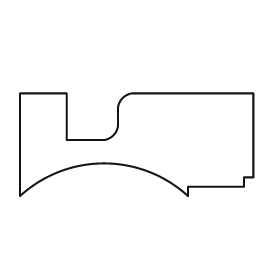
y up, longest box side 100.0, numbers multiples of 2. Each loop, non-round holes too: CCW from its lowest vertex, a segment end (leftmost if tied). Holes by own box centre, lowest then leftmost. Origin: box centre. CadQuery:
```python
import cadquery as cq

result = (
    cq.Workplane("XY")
    .moveTo(-50.0, -22.0)
    .threePointArc((-14.0, -8.0), (22.0, -22.0))
    .lineTo(22.0, -18.0)
    .lineTo(46.0, -18.0)
    .lineTo(46.0, -14.0)
    .lineTo(50.0, -14.0)
    .lineTo(50.0, 22.0)
    .lineTo(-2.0, 22.0)
    .threePointArc((-6.0, 20.0), (-8.0, 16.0))
    .lineTo(-8.0, 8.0)
    .threePointArc((-10.0, 4.0), (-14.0, 2.0))
    .lineTo(-30.0, 2.0)
    .lineTo(-30.0, 22.0)
    .lineTo(-50.0, 22.0)
    .close()
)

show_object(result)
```